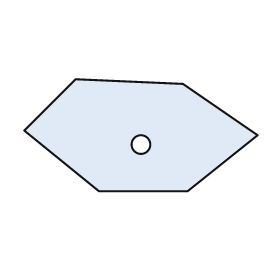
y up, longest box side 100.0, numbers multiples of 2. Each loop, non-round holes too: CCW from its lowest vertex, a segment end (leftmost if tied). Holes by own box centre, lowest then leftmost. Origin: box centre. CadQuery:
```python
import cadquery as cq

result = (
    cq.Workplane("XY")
    .moveTo(-18.0, -24.0)
    .lineTo(20.0, -24.0)
    .lineTo(50.0, 0.0)
    .lineTo(18.0, 22.0)
    .lineTo(-28.0, 24.0)
    .lineTo(-50.0, 2.0)
    .close()
    .moveTo(0.0, -4.0)
    .circle(4.0)
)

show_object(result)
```